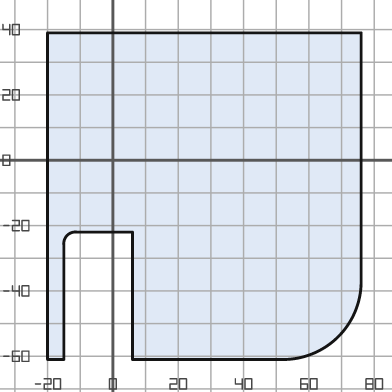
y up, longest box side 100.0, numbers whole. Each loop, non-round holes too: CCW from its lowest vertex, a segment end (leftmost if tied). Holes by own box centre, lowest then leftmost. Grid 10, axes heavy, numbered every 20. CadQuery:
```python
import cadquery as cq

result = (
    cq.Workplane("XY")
    .moveTo(-20.0, -61.0)
    .lineTo(-15.0, -61.0)
    .lineTo(-15.0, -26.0)
    .threePointArc((-14.0, -23.0), (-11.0, -22.0))
    .lineTo(6.0, -22.0)
    .lineTo(6.0, -61.0)
    .lineTo(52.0, -61.0)
    .threePointArc((69.0, -54.0), (76.0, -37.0))
    .lineTo(76.0, 39.0)
    .lineTo(-20.0, 39.0)
    .close()
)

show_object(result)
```